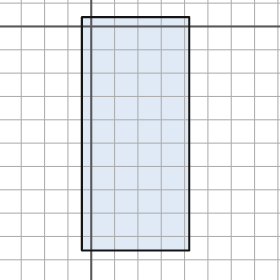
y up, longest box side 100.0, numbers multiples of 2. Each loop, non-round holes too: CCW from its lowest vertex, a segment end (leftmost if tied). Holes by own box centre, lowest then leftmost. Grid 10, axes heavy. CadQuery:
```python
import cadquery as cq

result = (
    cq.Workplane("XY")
    .moveTo(-4.0, -96.0)
    .lineTo(42.0, -96.0)
    .lineTo(42.0, 4.0)
    .lineTo(-4.0, 4.0)
    .close()
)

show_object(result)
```